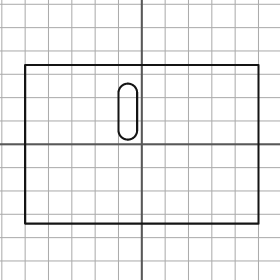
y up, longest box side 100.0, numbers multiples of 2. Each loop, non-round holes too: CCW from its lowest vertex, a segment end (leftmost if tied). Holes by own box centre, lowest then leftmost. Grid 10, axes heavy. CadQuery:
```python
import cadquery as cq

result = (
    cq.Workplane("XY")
    .moveTo(-50.0, -34.0)
    .lineTo(50.0, -34.0)
    .lineTo(50.0, 34.0)
    .lineTo(-50.0, 34.0)
    .close()
    .moveTo(-10.0, 6.0)
    .threePointArc((-6.0, 2.0), (-2.0, 6.0))
    .lineTo(-2.0, 22.0)
    .threePointArc((-6.0, 26.0), (-10.0, 22.0))
    .close()
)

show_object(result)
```